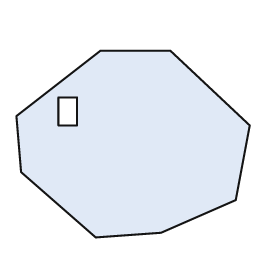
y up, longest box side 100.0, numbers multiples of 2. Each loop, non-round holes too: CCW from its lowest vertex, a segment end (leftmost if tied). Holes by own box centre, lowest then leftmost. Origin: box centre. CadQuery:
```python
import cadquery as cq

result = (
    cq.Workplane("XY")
    .moveTo(-16.0, -40.0)
    .lineTo(12.0, -38.0)
    .lineTo(44.0, -24.0)
    .lineTo(50.0, 8.0)
    .lineTo(16.0, 40.0)
    .lineTo(-14.0, 40.0)
    .lineTo(-50.0, 12.0)
    .lineTo(-48.0, -12.0)
    .close()
    .moveTo(-32.0, 8.0)
    .lineTo(-24.0, 8.0)
    .lineTo(-24.0, 20.0)
    .lineTo(-32.0, 20.0)
    .close()
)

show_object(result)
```